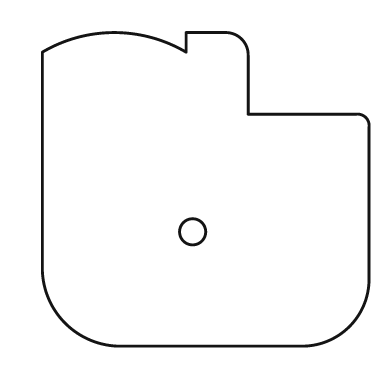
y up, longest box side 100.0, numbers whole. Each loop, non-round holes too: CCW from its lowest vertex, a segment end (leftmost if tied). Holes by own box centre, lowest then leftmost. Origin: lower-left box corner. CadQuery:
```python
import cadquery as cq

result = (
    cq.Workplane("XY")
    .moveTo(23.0, 0.0)
    .lineTo(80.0, 0.0)
    .threePointArc((94.0, 6.0), (100.0, 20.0))
    .lineTo(100.0, 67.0)
    .threePointArc((99.0, 70.0), (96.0, 71.0))
    .lineTo(63.0, 71.0)
    .lineTo(63.0, 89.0)
    .threePointArc((61.0, 94.0), (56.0, 96.0))
    .lineTo(44.0, 96.0)
    .lineTo(44.0, 90.0)
    .threePointArc((22.0, 96.0), (0.0, 90.0))
    .lineTo(0.0, 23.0)
    .threePointArc((7.0, 7.0), (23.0, 0.0))
    .close()
    .moveTo(46.0, 35.0)
    .circle(4.0)
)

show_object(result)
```